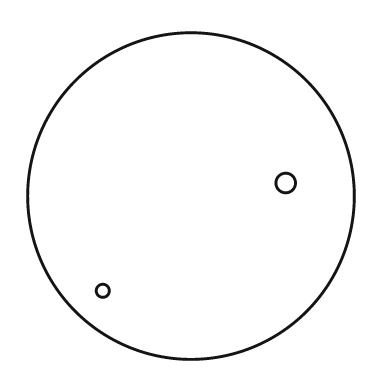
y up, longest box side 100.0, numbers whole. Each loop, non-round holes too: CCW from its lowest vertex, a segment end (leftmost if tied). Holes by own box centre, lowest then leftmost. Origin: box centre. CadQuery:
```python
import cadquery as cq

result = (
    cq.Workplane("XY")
    .moveTo(0.0, 0.0)
    .circle(50.0)
    .moveTo(-27.0, -29.0)
    .circle(2.0)
    .moveTo(29.0, 4.0)
    .circle(3.0)
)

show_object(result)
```